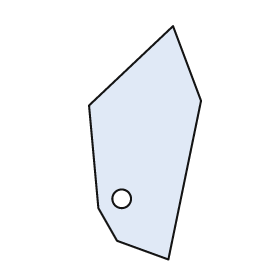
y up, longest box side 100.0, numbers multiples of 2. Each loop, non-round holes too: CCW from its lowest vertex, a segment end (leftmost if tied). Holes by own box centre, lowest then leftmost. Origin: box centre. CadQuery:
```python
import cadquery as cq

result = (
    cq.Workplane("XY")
    .moveTo(10.0, -50.0)
    .lineTo(24.0, 18.0)
    .lineTo(12.0, 50.0)
    .lineTo(-24.0, 16.0)
    .lineTo(-20.0, -28.0)
    .lineTo(-12.0, -42.0)
    .close()
    .moveTo(-10.0, -24.0)
    .circle(4.0)
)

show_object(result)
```